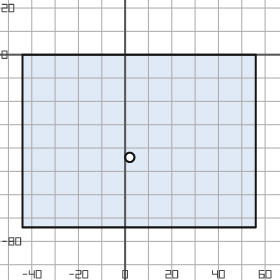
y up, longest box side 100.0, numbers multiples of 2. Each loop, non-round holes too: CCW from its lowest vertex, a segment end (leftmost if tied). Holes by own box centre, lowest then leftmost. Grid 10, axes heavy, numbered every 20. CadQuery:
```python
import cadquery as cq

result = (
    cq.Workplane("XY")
    .moveTo(-44.0, -74.0)
    .lineTo(56.0, -74.0)
    .lineTo(56.0, 0.0)
    .lineTo(-44.0, 0.0)
    .close()
    .moveTo(2.0, -44.0)
    .circle(2.0)
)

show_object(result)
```